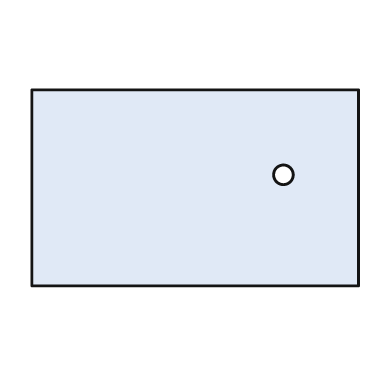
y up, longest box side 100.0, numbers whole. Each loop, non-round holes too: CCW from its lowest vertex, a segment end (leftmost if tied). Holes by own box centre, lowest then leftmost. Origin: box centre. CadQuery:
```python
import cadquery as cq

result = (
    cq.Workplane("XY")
    .moveTo(-50.0, -30.0)
    .lineTo(50.0, -30.0)
    .lineTo(50.0, 30.0)
    .lineTo(-50.0, 30.0)
    .close()
    .moveTo(27.0, 4.0)
    .circle(3.0)
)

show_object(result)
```